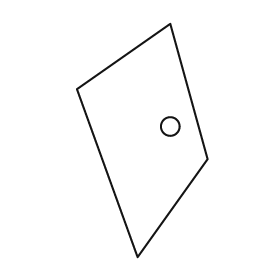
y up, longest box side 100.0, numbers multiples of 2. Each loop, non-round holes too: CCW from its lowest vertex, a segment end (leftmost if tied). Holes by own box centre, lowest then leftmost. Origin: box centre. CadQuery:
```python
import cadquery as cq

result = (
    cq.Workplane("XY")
    .moveTo(-2.0, -50.0)
    .lineTo(28.0, -8.0)
    .lineTo(12.0, 50.0)
    .lineTo(-28.0, 22.0)
    .close()
    .moveTo(12.0, 6.0)
    .circle(4.0)
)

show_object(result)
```